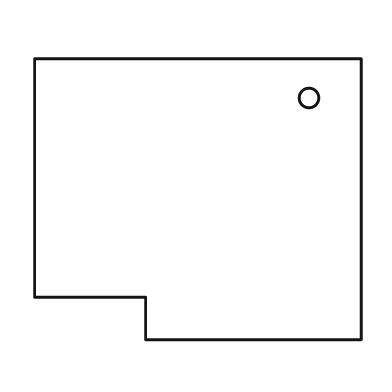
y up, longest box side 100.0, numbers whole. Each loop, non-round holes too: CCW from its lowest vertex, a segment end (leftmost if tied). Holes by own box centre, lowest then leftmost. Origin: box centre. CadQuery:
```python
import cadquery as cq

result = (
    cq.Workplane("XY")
    .moveTo(-16.0, -43.0)
    .lineTo(50.0, -43.0)
    .lineTo(50.0, 43.0)
    .lineTo(-50.0, 43.0)
    .lineTo(-50.0, -30.0)
    .lineTo(-16.0, -30.0)
    .close()
    .moveTo(34.0, 31.0)
    .circle(3.0)
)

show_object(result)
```